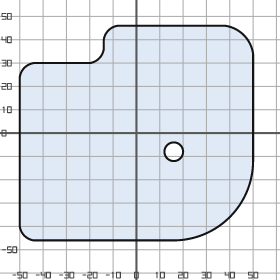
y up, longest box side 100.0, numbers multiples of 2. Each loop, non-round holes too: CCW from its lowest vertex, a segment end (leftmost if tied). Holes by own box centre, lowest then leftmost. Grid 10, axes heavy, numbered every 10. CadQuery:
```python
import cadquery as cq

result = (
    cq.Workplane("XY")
    .moveTo(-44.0, -46.0)
    .lineTo(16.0, -46.0)
    .threePointArc((40.0, -36.0), (50.0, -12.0))
    .lineTo(50.0, 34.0)
    .threePointArc((46.0, 42.0), (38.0, 46.0))
    .lineTo(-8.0, 46.0)
    .threePointArc((-12.0, 44.0), (-14.0, 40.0))
    .lineTo(-14.0, 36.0)
    .threePointArc((-16.0, 32.0), (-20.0, 30.0))
    .lineTo(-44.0, 30.0)
    .threePointArc((-48.0, 28.0), (-50.0, 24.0))
    .lineTo(-50.0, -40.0)
    .threePointArc((-48.0, -44.0), (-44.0, -46.0))
    .close()
    .moveTo(16.0, -8.0)
    .circle(4.0)
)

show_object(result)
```